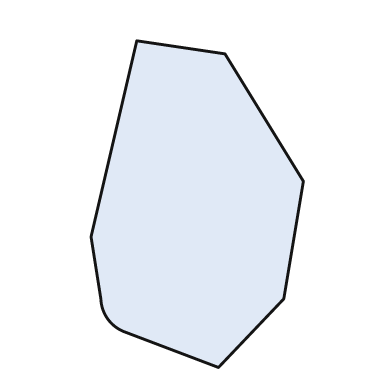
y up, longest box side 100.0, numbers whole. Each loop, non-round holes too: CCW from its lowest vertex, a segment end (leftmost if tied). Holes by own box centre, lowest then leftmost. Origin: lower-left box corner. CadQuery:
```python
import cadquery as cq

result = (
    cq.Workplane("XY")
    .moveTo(39.0, 0.0)
    .lineTo(59.0, 21.0)
    .lineTo(65.0, 57.0)
    .lineTo(41.0, 96.0)
    .lineTo(14.0, 100.0)
    .lineTo(0.0, 40.0)
    .lineTo(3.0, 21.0)
    .threePointArc((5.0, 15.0), (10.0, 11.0))
    .close()
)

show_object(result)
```